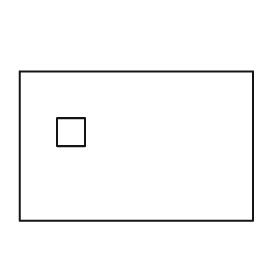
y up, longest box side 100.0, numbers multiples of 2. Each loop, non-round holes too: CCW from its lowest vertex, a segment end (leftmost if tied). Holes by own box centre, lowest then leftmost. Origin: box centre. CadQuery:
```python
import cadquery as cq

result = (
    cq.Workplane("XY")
    .moveTo(-50.0, -32.0)
    .lineTo(50.0, -32.0)
    .lineTo(50.0, 32.0)
    .lineTo(-50.0, 32.0)
    .close()
    .moveTo(-34.0, 0.0)
    .lineTo(-22.0, 0.0)
    .lineTo(-22.0, 12.0)
    .lineTo(-34.0, 12.0)
    .close()
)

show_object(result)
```